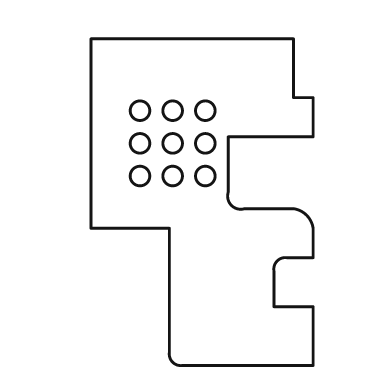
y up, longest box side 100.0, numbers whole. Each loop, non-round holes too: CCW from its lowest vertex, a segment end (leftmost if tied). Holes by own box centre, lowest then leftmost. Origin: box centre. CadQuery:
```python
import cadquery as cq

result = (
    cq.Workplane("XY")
    .moveTo(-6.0, -50.0)
    .lineTo(34.0, -50.0)
    .lineTo(34.0, -32.0)
    .lineTo(22.0, -32.0)
    .lineTo(22.0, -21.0)
    .threePointArc((23.0, -18.0), (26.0, -17.0))
    .lineTo(34.0, -17.0)
    .lineTo(34.0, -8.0)
    .threePointArc((32.0, -4.0), (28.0, -2.0))
    .lineTo(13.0, -2.0)
    .threePointArc((9.0, -1.0), (8.0, 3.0))
    .lineTo(8.0, 20.0)
    .lineTo(34.0, 20.0)
    .lineTo(34.0, 32.0)
    .lineTo(28.0, 32.0)
    .lineTo(28.0, 50.0)
    .lineTo(-34.0, 50.0)
    .lineTo(-34.0, -8.0)
    .lineTo(-10.0, -8.0)
    .lineTo(-10.0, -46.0)
    .threePointArc((-9.0, -49.0), (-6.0, -50.0))
    .close()
    .moveTo(-19.0, 8.0)
    .circle(3.0)
    .moveTo(-9.0, 8.0)
    .circle(3.0)
    .moveTo(1.0, 8.0)
    .circle(3.0)
    .moveTo(-19.0, 18.0)
    .circle(3.0)
    .moveTo(-9.0, 18.0)
    .circle(3.0)
    .moveTo(1.0, 18.0)
    .circle(3.0)
    .moveTo(-19.0, 28.0)
    .circle(3.0)
    .moveTo(-9.0, 28.0)
    .circle(3.0)
    .moveTo(1.0, 28.0)
    .circle(3.0)
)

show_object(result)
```